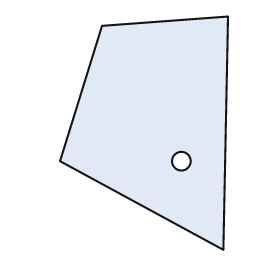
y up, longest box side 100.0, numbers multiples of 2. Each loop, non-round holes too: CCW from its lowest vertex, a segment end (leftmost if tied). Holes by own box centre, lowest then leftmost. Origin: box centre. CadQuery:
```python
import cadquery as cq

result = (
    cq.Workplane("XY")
    .moveTo(34.0, -50.0)
    .lineTo(36.0, 50.0)
    .lineTo(-18.0, 46.0)
    .lineTo(-36.0, -12.0)
    .close()
    .moveTo(16.0, -12.0)
    .circle(4.0)
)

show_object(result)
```